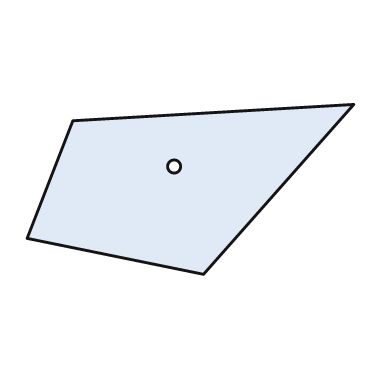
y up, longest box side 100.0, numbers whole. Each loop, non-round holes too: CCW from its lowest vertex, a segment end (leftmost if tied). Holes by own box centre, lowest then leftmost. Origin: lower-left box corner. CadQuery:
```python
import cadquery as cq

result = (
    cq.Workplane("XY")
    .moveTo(54.0, 0.0)
    .lineTo(100.0, 52.0)
    .lineTo(14.0, 47.0)
    .lineTo(0.0, 11.0)
    .close()
    .moveTo(45.0, 33.0)
    .circle(2.0)
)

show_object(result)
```